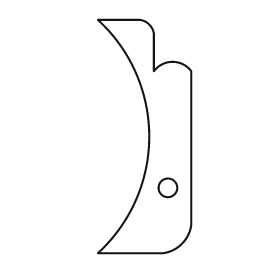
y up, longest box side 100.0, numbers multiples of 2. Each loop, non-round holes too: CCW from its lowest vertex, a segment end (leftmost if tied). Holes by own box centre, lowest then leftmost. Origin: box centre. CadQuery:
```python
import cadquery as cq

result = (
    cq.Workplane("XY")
    .moveTo(-20.0, -50.0)
    .lineTo(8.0, -50.0)
    .threePointArc((16.0, -46.0), (20.0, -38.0))
    .lineTo(20.0, 28.0)
    .threePointArc((12.0, 32.0), (4.0, 28.0))
    .lineTo(4.0, 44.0)
    .threePointArc((2.0, 48.0), (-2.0, 50.0))
    .lineTo(-20.0, 50.0)
    .threePointArc((2.0, 0.0), (-20.0, -50.0))
    .close()
    .moveTo(10.0, -22.0)
    .circle(4.0)
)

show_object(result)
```